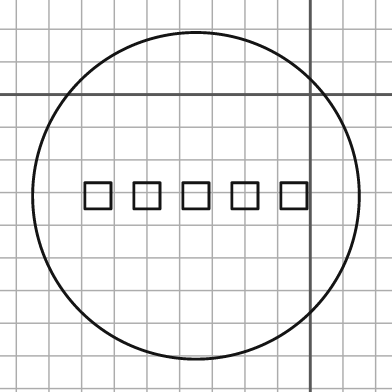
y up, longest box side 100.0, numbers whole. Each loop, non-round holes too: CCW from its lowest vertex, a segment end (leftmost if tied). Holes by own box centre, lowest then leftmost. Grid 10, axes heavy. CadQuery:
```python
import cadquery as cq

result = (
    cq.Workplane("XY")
    .moveTo(-35.0, -31.0)
    .circle(50.0)
    .moveTo(-69.0, -35.0)
    .lineTo(-61.0, -35.0)
    .lineTo(-61.0, -27.0)
    .lineTo(-69.0, -27.0)
    .close()
    .moveTo(-54.0, -35.0)
    .lineTo(-46.0, -35.0)
    .lineTo(-46.0, -27.0)
    .lineTo(-54.0, -27.0)
    .close()
    .moveTo(-39.0, -35.0)
    .lineTo(-31.0, -35.0)
    .lineTo(-31.0, -27.0)
    .lineTo(-39.0, -27.0)
    .close()
    .moveTo(-24.0, -35.0)
    .lineTo(-16.0, -35.0)
    .lineTo(-16.0, -27.0)
    .lineTo(-24.0, -27.0)
    .close()
    .moveTo(-9.0, -35.0)
    .lineTo(-1.0, -35.0)
    .lineTo(-1.0, -27.0)
    .lineTo(-9.0, -27.0)
    .close()
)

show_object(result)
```